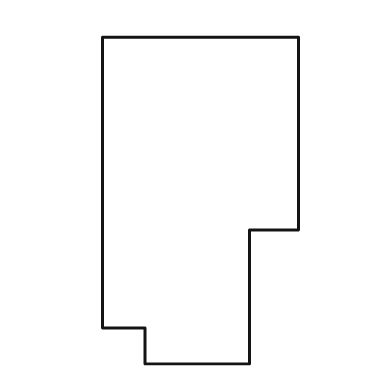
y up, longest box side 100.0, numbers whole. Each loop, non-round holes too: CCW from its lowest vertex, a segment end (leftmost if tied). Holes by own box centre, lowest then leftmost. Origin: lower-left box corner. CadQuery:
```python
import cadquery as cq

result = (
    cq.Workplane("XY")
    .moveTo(13.0, 0.0)
    .lineTo(45.0, 0.0)
    .lineTo(45.0, 41.0)
    .lineTo(60.0, 41.0)
    .lineTo(60.0, 100.0)
    .lineTo(0.0, 100.0)
    .lineTo(0.0, 11.0)
    .lineTo(13.0, 11.0)
    .close()
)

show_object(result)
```